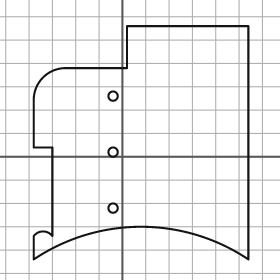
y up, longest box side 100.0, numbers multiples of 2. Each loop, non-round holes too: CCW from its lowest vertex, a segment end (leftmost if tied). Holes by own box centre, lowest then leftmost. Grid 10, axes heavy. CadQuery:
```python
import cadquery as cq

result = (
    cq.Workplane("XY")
    .moveTo(-38.0, -44.0)
    .threePointArc((8.0, -30.0), (54.0, -44.0))
    .lineTo(54.0, 56.0)
    .lineTo(2.0, 56.0)
    .lineTo(2.0, 38.0)
    .lineTo(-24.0, 38.0)
    .threePointArc((-34.0, 34.0), (-38.0, 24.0))
    .lineTo(-38.0, 4.0)
    .lineTo(-30.0, 4.0)
    .lineTo(-30.0, -34.0)
    .threePointArc((-34.0, -32.0), (-38.0, -34.0))
    .close()
    .moveTo(-4.0, -22.0)
    .circle(2.0)
    .moveTo(-4.0, 2.0)
    .circle(2.0)
    .moveTo(-4.0, 26.0)
    .circle(2.0)
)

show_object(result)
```